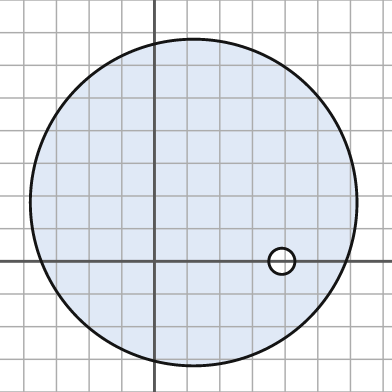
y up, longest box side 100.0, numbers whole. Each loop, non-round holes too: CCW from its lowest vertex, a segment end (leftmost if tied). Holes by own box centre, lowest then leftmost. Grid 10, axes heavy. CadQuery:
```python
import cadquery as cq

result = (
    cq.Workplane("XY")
    .moveTo(12.0, 18.0)
    .circle(50.0)
    .moveTo(39.0, 0.0)
    .circle(4.0)
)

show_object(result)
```